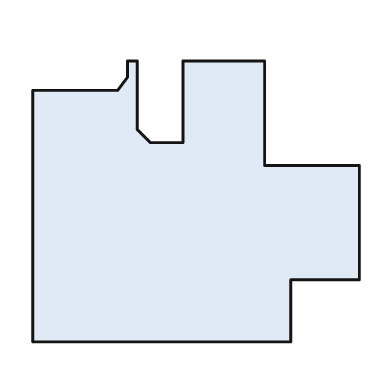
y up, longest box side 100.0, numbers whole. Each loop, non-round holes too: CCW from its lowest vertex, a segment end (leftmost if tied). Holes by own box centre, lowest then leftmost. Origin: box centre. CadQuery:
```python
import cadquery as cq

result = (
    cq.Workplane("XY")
    .moveTo(-50.0, -43.0)
    .lineTo(29.0, -43.0)
    .lineTo(29.0, -24.0)
    .lineTo(50.0, -24.0)
    .lineTo(50.0, 11.0)
    .lineTo(21.0, 11.0)
    .lineTo(21.0, 43.0)
    .lineTo(-4.0, 43.0)
    .lineTo(-4.0, 18.0)
    .lineTo(-14.0, 18.0)
    .lineTo(-18.0, 22.0)
    .lineTo(-18.0, 43.0)
    .lineTo(-21.0, 43.0)
    .lineTo(-21.0, 38.0)
    .lineTo(-24.0, 34.0)
    .lineTo(-50.0, 34.0)
    .close()
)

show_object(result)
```